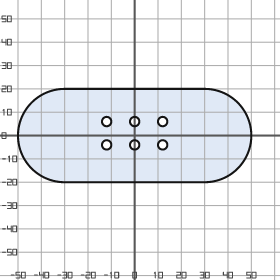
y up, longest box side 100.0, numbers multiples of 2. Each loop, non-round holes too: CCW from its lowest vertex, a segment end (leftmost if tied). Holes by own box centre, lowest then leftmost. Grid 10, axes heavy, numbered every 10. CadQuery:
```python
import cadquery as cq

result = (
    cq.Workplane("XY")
    .moveTo(-30.0, -20.0)
    .lineTo(30.0, -20.0)
    .threePointArc((50.0, 0.0), (30.0, 20.0))
    .lineTo(-30.0, 20.0)
    .threePointArc((-50.0, 0.0), (-30.0, -20.0))
    .close()
    .moveTo(-12.0, -4.0)
    .circle(2.0)
    .moveTo(0.0, -4.0)
    .circle(2.0)
    .moveTo(12.0, -4.0)
    .circle(2.0)
    .moveTo(-12.0, 6.0)
    .circle(2.0)
    .moveTo(0.0, 6.0)
    .circle(2.0)
    .moveTo(12.0, 6.0)
    .circle(2.0)
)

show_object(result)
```